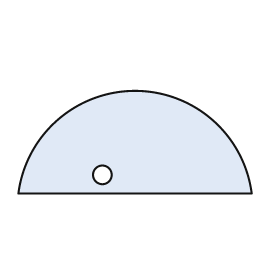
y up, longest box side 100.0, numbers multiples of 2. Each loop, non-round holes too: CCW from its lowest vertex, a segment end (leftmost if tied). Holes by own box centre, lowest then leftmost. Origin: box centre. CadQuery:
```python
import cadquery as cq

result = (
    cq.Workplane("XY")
    .moveTo(-50.0, -22.0)
    .lineTo(50.0, -22.0)
    .threePointArc((0.0, 22.0), (-50.0, -22.0))
    .close()
    .moveTo(-14.0, -14.0)
    .circle(4.0)
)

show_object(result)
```